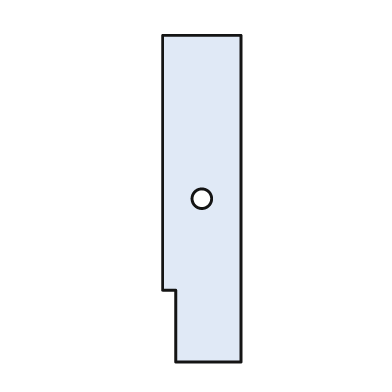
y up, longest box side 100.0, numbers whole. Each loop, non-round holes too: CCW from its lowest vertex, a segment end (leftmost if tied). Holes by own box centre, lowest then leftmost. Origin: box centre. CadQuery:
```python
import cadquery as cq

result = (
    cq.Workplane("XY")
    .moveTo(-8.0, -50.0)
    .lineTo(12.0, -50.0)
    .lineTo(12.0, 50.0)
    .lineTo(-12.0, 50.0)
    .lineTo(-12.0, -28.0)
    .lineTo(-8.0, -28.0)
    .close()
    .moveTo(0.0, 0.0)
    .circle(3.0)
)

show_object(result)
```